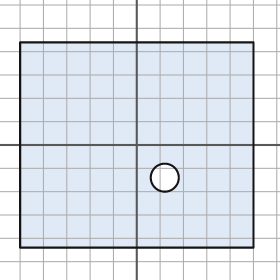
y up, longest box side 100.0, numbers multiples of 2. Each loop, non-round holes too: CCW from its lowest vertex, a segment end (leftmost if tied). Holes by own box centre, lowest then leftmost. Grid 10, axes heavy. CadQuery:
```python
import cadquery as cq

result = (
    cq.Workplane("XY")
    .moveTo(-50.0, -44.0)
    .lineTo(50.0, -44.0)
    .lineTo(50.0, 44.0)
    .lineTo(-50.0, 44.0)
    .close()
    .moveTo(12.0, -14.0)
    .circle(6.0)
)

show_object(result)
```